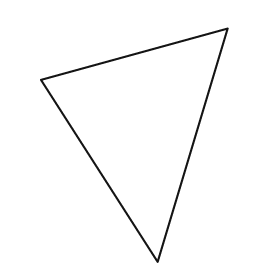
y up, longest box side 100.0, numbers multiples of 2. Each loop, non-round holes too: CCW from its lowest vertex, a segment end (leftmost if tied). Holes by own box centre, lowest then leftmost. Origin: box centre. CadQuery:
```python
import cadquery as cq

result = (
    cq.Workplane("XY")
    .moveTo(10.0, -50.0)
    .lineTo(40.0, 50.0)
    .lineTo(-40.0, 28.0)
    .close()
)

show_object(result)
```